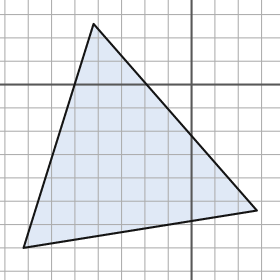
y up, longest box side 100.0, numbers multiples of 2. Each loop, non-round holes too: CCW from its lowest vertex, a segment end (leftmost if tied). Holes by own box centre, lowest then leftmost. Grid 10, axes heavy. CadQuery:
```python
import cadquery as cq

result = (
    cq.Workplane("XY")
    .moveTo(-72.0, -70.0)
    .lineTo(28.0, -54.0)
    .lineTo(-42.0, 26.0)
    .close()
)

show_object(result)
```